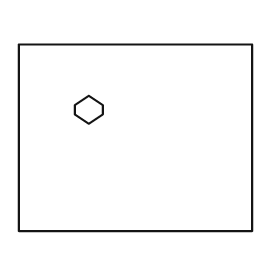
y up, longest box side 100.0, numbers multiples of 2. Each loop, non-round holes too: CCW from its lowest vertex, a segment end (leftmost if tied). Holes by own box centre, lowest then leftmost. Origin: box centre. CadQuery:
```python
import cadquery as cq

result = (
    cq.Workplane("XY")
    .moveTo(-50.0, -40.0)
    .lineTo(50.0, -40.0)
    .lineTo(50.0, 40.0)
    .lineTo(-50.0, 40.0)
    .close()
    .moveTo(-20.0, 6.0)
    .lineTo(-14.0, 10.0)
    .lineTo(-14.0, 14.0)
    .lineTo(-20.0, 18.0)
    .lineTo(-26.0, 14.0)
    .lineTo(-26.0, 10.0)
    .close()
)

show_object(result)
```